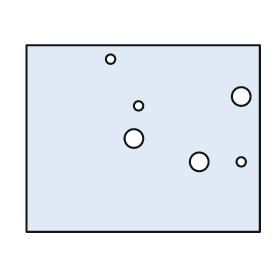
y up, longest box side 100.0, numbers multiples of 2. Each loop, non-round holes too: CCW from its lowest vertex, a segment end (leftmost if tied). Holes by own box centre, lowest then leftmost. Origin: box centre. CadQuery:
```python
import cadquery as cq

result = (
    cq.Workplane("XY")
    .moveTo(-50.0, -40.0)
    .lineTo(50.0, -40.0)
    .lineTo(50.0, 40.0)
    .lineTo(-50.0, 40.0)
    .close()
    .moveTo(24.0, -10.0)
    .circle(4.0)
    .moveTo(42.0, -10.0)
    .circle(2.0)
    .moveTo(-4.0, 0.0)
    .circle(4.0)
    .moveTo(-2.0, 14.0)
    .circle(2.0)
    .moveTo(42.0, 18.0)
    .circle(4.0)
    .moveTo(-14.0, 34.0)
    .circle(2.0)
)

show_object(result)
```